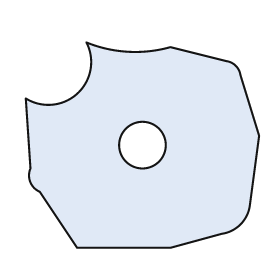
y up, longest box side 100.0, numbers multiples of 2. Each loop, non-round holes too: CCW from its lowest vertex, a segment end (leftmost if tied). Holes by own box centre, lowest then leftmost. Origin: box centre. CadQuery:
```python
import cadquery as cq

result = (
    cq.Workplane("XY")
    .moveTo(-28.0, -44.0)
    .lineTo(12.0, -44.0)
    .lineTo(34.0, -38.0)
    .threePointArc((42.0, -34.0), (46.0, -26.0))
    .lineTo(50.0, 4.0)
    .lineTo(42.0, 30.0)
    .threePointArc((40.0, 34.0), (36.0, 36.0))
    .lineTo(12.0, 42.0)
    .threePointArc((-6.0, 40.0), (-24.0, 44.0))
    .threePointArc((-28.0, 22.0), (-50.0, 20.0))
    .lineTo(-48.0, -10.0)
    .threePointArc((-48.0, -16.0), (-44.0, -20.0))
    .close()
    .moveTo(0.0, 0.0)
    .circle(10.0)
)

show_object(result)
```